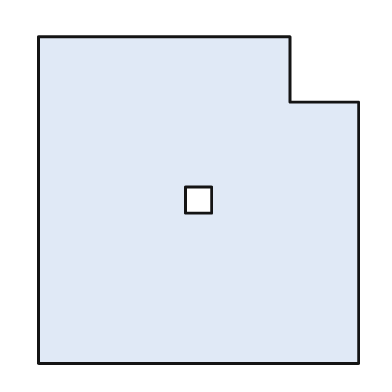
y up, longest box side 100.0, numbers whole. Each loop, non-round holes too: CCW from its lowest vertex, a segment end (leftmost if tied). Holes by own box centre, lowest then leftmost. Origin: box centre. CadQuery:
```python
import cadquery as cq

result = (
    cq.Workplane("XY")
    .moveTo(-49.0, -50.0)
    .lineTo(49.0, -50.0)
    .lineTo(49.0, 30.0)
    .lineTo(28.0, 30.0)
    .lineTo(28.0, 50.0)
    .lineTo(-49.0, 50.0)
    .close()
    .moveTo(-4.0, -4.0)
    .lineTo(4.0, -4.0)
    .lineTo(4.0, 4.0)
    .lineTo(-4.0, 4.0)
    .close()
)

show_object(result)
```